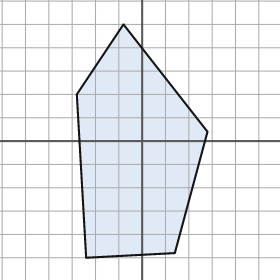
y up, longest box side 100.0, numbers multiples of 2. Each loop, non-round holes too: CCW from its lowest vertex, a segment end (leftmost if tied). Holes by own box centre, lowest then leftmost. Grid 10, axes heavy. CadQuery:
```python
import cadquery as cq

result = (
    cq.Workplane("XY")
    .moveTo(-24.0, -50.0)
    .lineTo(14.0, -48.0)
    .lineTo(28.0, 4.0)
    .lineTo(-8.0, 50.0)
    .lineTo(-28.0, 20.0)
    .close()
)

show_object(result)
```